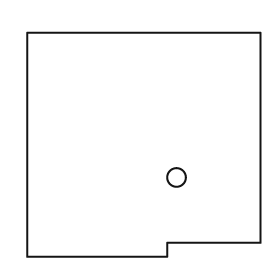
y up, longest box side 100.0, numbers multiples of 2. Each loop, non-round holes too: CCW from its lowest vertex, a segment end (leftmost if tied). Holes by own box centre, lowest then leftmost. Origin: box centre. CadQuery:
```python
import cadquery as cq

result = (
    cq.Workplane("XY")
    .moveTo(-50.0, -48.0)
    .lineTo(10.0, -48.0)
    .lineTo(10.0, -42.0)
    .lineTo(50.0, -42.0)
    .lineTo(50.0, 48.0)
    .lineTo(-50.0, 48.0)
    .close()
    .moveTo(14.0, -14.0)
    .circle(4.0)
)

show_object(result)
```